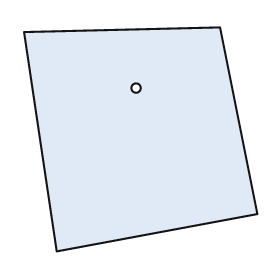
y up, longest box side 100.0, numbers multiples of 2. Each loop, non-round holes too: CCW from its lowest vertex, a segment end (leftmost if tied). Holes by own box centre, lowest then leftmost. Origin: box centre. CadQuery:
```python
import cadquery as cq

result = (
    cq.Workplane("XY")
    .moveTo(-36.0, -48.0)
    .lineTo(50.0, -32.0)
    .lineTo(34.0, 48.0)
    .lineTo(-50.0, 46.0)
    .close()
    .moveTo(-2.0, 22.0)
    .circle(2.0)
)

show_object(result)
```